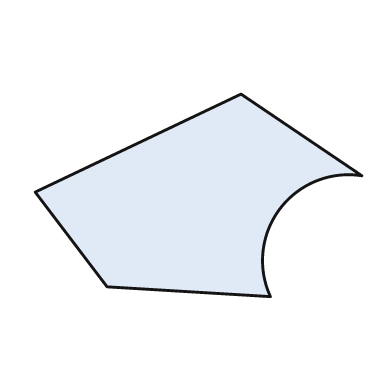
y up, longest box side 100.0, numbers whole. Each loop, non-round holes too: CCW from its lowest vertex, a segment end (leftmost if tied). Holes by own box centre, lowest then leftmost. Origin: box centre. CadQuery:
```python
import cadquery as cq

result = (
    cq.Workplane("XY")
    .moveTo(22.0, -31.0)
    .threePointArc((25.0, -4.0), (50.0, 6.0))
    .lineTo(13.0, 31.0)
    .lineTo(-50.0, 1.0)
    .lineTo(-28.0, -28.0)
    .close()
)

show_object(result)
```